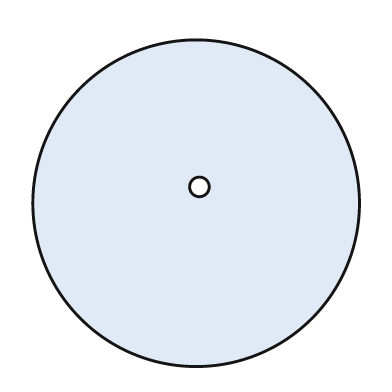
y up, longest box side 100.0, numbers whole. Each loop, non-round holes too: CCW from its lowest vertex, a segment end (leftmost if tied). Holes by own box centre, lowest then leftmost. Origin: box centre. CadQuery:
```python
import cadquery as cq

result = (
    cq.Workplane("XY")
    .moveTo(0.0, 0.0)
    .circle(50.0)
    .moveTo(1.0, 5.0)
    .circle(3.0)
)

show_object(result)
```